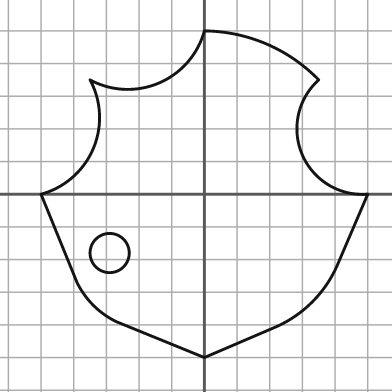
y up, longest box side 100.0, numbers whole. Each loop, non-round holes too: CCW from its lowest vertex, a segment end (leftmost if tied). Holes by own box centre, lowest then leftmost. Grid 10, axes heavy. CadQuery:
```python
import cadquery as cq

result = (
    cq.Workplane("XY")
    .moveTo(0.0, -50.0)
    .lineTo(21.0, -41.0)
    .threePointArc((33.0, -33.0), (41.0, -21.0))
    .lineTo(50.0, 0.0)
    .threePointArc((30.0, 12.0), (35.0, 35.0))
    .threePointArc((19.0, 46.0), (0.0, 50.0))
    .threePointArc((-14.0, 34.0), (-35.0, 35.0))
    .threePointArc((-34.0, 14.0), (-50.0, 0.0))
    .lineTo(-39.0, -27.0)
    .threePointArc((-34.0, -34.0), (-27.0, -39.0))
    .close()
    .moveTo(-29.0, -18.0)
    .circle(6.0)
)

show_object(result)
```